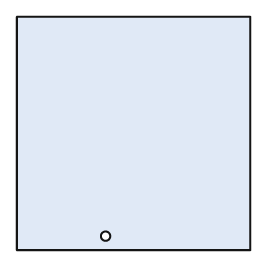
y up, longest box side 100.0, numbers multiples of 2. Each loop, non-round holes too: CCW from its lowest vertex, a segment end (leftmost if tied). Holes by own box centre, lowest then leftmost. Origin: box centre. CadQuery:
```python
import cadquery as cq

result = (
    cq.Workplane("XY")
    .moveTo(-50.0, -50.0)
    .lineTo(50.0, -50.0)
    .lineTo(50.0, 50.0)
    .lineTo(-50.0, 50.0)
    .close()
    .moveTo(-12.0, -44.0)
    .circle(2.0)
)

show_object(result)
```